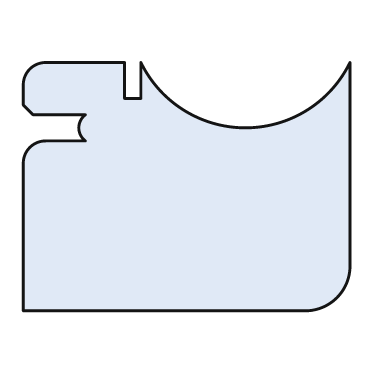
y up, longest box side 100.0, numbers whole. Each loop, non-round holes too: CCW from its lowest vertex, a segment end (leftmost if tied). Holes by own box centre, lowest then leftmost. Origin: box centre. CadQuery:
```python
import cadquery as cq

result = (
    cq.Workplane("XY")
    .moveTo(-50.0, -38.0)
    .lineTo(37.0, -38.0)
    .threePointArc((46.0, -34.0), (50.0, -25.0))
    .lineTo(50.0, 38.0)
    .threePointArc((18.0, 18.0), (-14.0, 38.0))
    .lineTo(-14.0, 27.0)
    .lineTo(-19.0, 27.0)
    .lineTo(-19.0, 38.0)
    .lineTo(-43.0, 38.0)
    .threePointArc((-48.0, 36.0), (-50.0, 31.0))
    .lineTo(-50.0, 25.0)
    .lineTo(-47.0, 22.0)
    .lineTo(-31.0, 22.0)
    .threePointArc((-33.0, 18.0), (-31.0, 14.0))
    .lineTo(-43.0, 14.0)
    .threePointArc((-48.0, 12.0), (-50.0, 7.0))
    .close()
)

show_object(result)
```